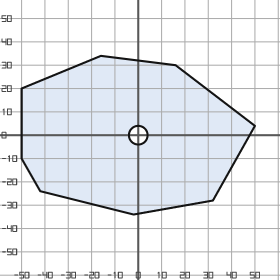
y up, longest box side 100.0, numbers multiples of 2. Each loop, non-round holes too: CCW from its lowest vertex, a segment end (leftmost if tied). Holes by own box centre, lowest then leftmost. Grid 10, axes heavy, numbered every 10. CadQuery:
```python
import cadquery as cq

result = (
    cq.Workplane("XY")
    .moveTo(-2.0, -34.0)
    .lineTo(32.0, -28.0)
    .lineTo(50.0, 4.0)
    .lineTo(16.0, 30.0)
    .lineTo(-16.0, 34.0)
    .lineTo(-50.0, 20.0)
    .lineTo(-50.0, -10.0)
    .lineTo(-42.0, -24.0)
    .close()
    .moveTo(0.0, 0.0)
    .circle(4.0)
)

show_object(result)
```